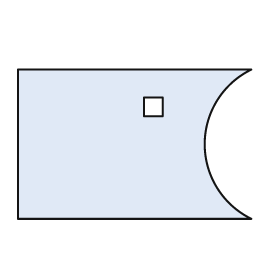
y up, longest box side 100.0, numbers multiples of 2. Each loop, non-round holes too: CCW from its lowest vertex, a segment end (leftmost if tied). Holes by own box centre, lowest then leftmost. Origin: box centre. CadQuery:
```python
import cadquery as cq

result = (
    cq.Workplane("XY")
    .moveTo(-50.0, -32.0)
    .lineTo(50.0, -32.0)
    .threePointArc((30.0, 0.0), (50.0, 32.0))
    .lineTo(-50.0, 32.0)
    .close()
    .moveTo(4.0, 12.0)
    .lineTo(12.0, 12.0)
    .lineTo(12.0, 20.0)
    .lineTo(4.0, 20.0)
    .close()
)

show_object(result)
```